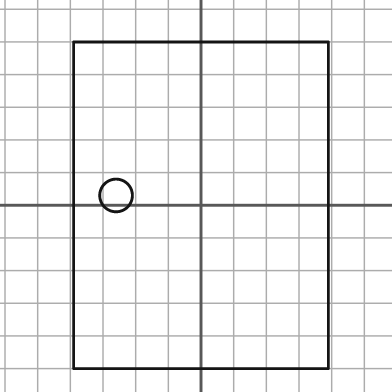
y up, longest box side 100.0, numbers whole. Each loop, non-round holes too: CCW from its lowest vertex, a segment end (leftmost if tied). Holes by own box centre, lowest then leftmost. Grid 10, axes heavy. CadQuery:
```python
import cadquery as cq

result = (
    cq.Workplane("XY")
    .moveTo(-39.0, -50.0)
    .lineTo(39.0, -50.0)
    .lineTo(39.0, 50.0)
    .lineTo(-39.0, 50.0)
    .close()
    .moveTo(-26.0, 3.0)
    .circle(5.0)
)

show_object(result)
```